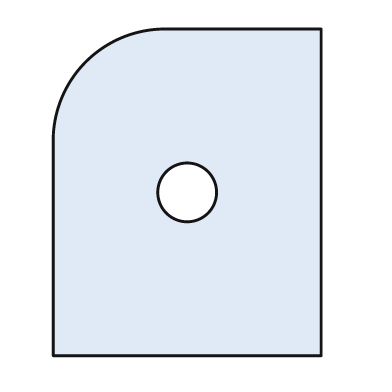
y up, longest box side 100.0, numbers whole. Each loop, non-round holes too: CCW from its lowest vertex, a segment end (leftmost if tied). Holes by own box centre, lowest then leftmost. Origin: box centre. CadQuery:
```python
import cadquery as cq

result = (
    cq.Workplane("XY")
    .moveTo(-41.0, -50.0)
    .lineTo(41.0, -50.0)
    .lineTo(41.0, 50.0)
    .lineTo(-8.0, 50.0)
    .threePointArc((-31.0, 40.0), (-41.0, 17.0))
    .close()
    .moveTo(0.0, 0.0)
    .circle(9.0)
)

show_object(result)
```